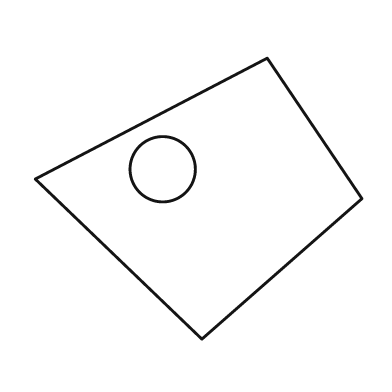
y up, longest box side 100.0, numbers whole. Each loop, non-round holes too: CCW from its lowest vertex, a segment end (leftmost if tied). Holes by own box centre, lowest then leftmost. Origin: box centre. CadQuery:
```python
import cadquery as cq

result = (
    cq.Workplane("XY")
    .moveTo(1.0, -43.0)
    .lineTo(50.0, 0.0)
    .lineTo(21.0, 43.0)
    .lineTo(-50.0, 6.0)
    .close()
    .moveTo(-11.0, 9.0)
    .circle(10.0)
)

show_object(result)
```